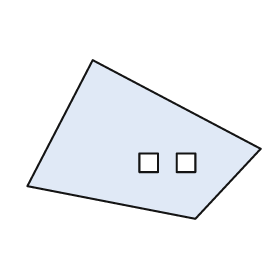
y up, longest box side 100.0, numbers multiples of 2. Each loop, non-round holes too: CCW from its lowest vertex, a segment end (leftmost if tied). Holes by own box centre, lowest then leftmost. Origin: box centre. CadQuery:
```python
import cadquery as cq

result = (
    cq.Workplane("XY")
    .moveTo(22.0, -34.0)
    .lineTo(50.0, -4.0)
    .lineTo(-22.0, 34.0)
    .lineTo(-50.0, -20.0)
    .close()
    .moveTo(-2.0, -14.0)
    .lineTo(6.0, -14.0)
    .lineTo(6.0, -6.0)
    .lineTo(-2.0, -6.0)
    .close()
    .moveTo(14.0, -14.0)
    .lineTo(22.0, -14.0)
    .lineTo(22.0, -6.0)
    .lineTo(14.0, -6.0)
    .close()
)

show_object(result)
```